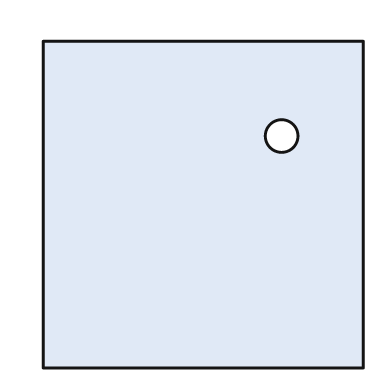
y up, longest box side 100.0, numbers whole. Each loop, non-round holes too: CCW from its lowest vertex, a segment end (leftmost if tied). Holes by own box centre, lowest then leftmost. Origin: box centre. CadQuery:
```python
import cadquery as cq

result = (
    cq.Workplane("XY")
    .moveTo(-49.0, -50.0)
    .lineTo(49.0, -50.0)
    .lineTo(49.0, 50.0)
    .lineTo(-49.0, 50.0)
    .close()
    .moveTo(24.0, 21.0)
    .circle(5.0)
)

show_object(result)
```